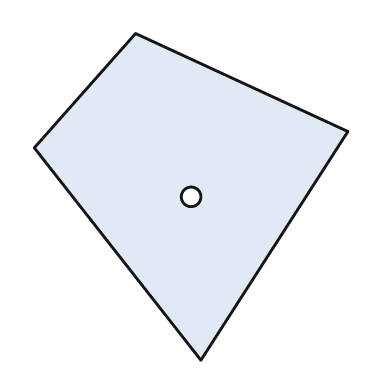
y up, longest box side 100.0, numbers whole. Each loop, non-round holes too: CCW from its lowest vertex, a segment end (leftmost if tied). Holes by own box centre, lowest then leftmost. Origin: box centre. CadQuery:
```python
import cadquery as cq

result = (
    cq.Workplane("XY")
    .moveTo(3.0, -50.0)
    .lineTo(48.0, 20.0)
    .lineTo(-17.0, 50.0)
    .lineTo(-48.0, 15.0)
    .close()
    .moveTo(0.0, 0.0)
    .circle(3.0)
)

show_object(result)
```